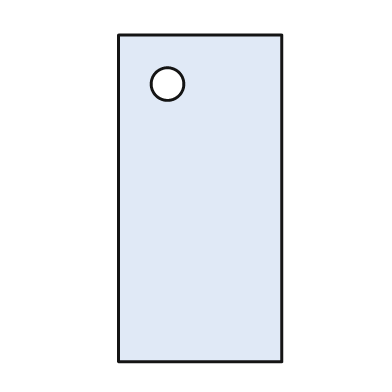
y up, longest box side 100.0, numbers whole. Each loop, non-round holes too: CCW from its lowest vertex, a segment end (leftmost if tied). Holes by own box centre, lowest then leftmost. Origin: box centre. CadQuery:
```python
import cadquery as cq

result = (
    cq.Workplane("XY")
    .moveTo(-25.0, -50.0)
    .lineTo(25.0, -50.0)
    .lineTo(25.0, 50.0)
    .lineTo(-25.0, 50.0)
    .close()
    .moveTo(-10.0, 35.0)
    .circle(5.0)
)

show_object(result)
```